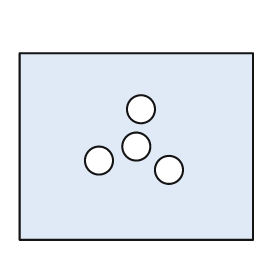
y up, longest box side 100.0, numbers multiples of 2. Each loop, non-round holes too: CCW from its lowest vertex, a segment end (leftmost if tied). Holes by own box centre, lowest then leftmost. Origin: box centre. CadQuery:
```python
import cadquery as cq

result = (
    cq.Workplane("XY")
    .moveTo(-50.0, -40.0)
    .lineTo(50.0, -40.0)
    .lineTo(50.0, 40.0)
    .lineTo(-50.0, 40.0)
    .close()
    .moveTo(14.0, -10.0)
    .circle(6.0)
    .moveTo(-16.0, -6.0)
    .circle(6.0)
    .moveTo(0.0, 0.0)
    .circle(6.0)
    .moveTo(2.0, 16.0)
    .circle(6.0)
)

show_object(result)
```